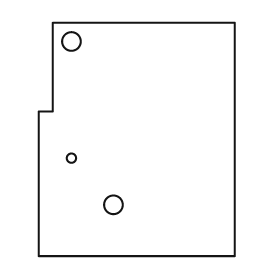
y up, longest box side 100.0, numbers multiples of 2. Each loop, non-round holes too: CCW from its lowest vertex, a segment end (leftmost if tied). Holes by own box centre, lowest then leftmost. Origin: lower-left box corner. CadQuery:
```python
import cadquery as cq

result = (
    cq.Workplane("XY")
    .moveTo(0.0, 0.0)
    .lineTo(84.0, 0.0)
    .lineTo(84.0, 100.0)
    .lineTo(6.0, 100.0)
    .lineTo(6.0, 62.0)
    .lineTo(0.0, 62.0)
    .close()
    .moveTo(32.0, 22.0)
    .circle(4.0)
    .moveTo(14.0, 42.0)
    .circle(2.0)
    .moveTo(14.0, 92.0)
    .circle(4.0)
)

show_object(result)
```